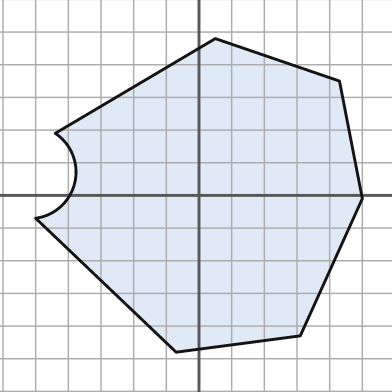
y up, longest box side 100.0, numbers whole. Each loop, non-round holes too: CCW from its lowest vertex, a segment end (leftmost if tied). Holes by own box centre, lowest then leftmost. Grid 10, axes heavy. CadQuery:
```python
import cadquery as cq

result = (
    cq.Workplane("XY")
    .moveTo(-7.0, -48.0)
    .lineTo(31.0, -43.0)
    .lineTo(50.0, -1.0)
    .lineTo(43.0, 35.0)
    .lineTo(5.0, 48.0)
    .lineTo(-44.0, 19.0)
    .threePointArc((-38.0, 4.0), (-50.0, -7.0))
    .close()
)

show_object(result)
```